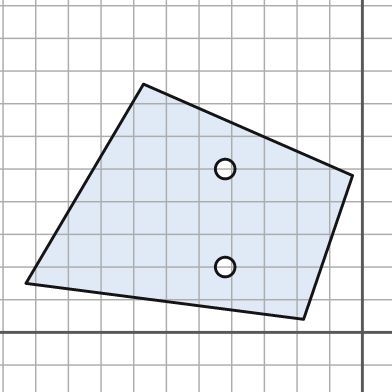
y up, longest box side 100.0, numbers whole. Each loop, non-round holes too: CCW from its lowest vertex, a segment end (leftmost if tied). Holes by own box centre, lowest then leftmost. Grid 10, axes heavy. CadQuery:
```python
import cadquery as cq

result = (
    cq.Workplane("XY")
    .moveTo(-18.0, 4.0)
    .lineTo(-3.0, 48.0)
    .lineTo(-67.0, 76.0)
    .lineTo(-103.0, 15.0)
    .close()
    .moveTo(-42.0, 20.0)
    .circle(3.0)
    .moveTo(-42.0, 50.0)
    .circle(3.0)
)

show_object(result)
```